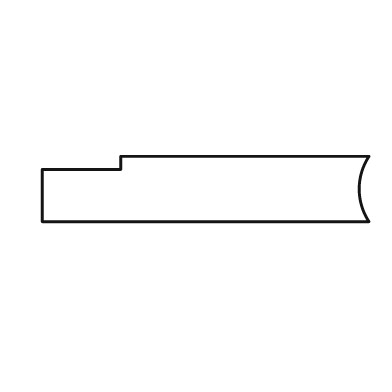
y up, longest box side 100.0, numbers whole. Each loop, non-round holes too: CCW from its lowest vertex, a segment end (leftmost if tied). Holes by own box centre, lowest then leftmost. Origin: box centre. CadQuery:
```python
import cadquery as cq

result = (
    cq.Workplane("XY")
    .moveTo(-50.0, -10.0)
    .lineTo(50.0, -10.0)
    .threePointArc((47.0, 0.0), (50.0, 10.0))
    .lineTo(-26.0, 10.0)
    .lineTo(-26.0, 6.0)
    .lineTo(-50.0, 6.0)
    .close()
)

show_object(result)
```